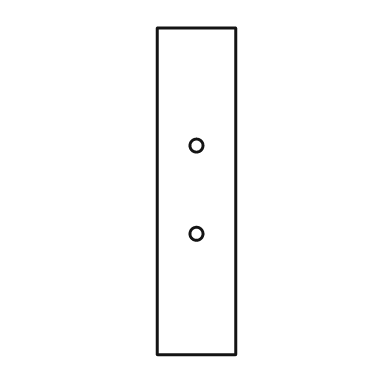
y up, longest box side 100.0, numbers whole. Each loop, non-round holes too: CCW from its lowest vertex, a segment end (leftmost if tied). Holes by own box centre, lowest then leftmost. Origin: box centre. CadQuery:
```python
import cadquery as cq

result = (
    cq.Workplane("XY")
    .moveTo(-12.0, -50.0)
    .lineTo(12.0, -50.0)
    .lineTo(12.0, 50.0)
    .lineTo(-12.0, 50.0)
    .close()
    .moveTo(0.0, -13.0)
    .circle(2.0)
    .moveTo(0.0, 14.0)
    .circle(2.0)
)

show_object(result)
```